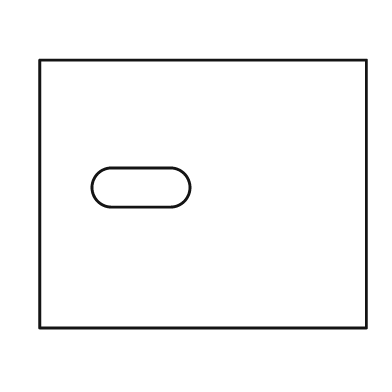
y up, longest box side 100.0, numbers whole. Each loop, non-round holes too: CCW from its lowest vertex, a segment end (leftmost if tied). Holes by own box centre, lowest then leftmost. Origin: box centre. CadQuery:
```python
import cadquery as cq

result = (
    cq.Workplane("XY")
    .moveTo(-50.0, -41.0)
    .lineTo(50.0, -41.0)
    .lineTo(50.0, 41.0)
    .lineTo(-50.0, 41.0)
    .close()
    .moveTo(-28.0, -4.0)
    .lineTo(-10.0, -4.0)
    .threePointArc((-4.0, 2.0), (-10.0, 8.0))
    .lineTo(-28.0, 8.0)
    .threePointArc((-34.0, 2.0), (-28.0, -4.0))
    .close()
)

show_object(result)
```